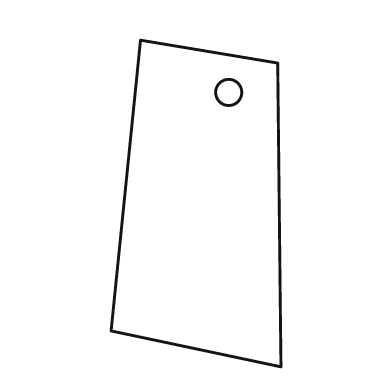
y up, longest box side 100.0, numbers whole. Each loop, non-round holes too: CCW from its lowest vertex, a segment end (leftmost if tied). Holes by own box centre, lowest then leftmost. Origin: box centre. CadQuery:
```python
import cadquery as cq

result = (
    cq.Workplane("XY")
    .moveTo(26.0, -50.0)
    .lineTo(25.0, 43.0)
    .lineTo(-17.0, 50.0)
    .lineTo(-26.0, -39.0)
    .close()
    .moveTo(10.0, 34.0)
    .circle(4.0)
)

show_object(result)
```